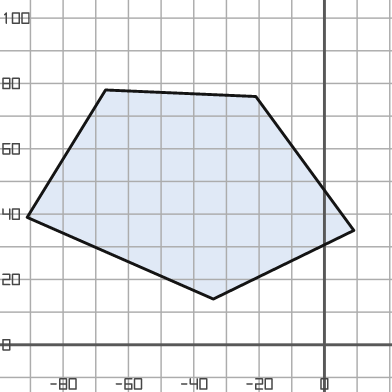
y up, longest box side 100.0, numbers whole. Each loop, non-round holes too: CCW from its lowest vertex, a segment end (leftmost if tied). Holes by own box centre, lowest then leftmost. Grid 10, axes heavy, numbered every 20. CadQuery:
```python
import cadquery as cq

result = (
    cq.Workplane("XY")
    .moveTo(-34.0, 14.0)
    .lineTo(9.0, 35.0)
    .lineTo(-21.0, 76.0)
    .lineTo(-67.0, 78.0)
    .lineTo(-91.0, 39.0)
    .close()
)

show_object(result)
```